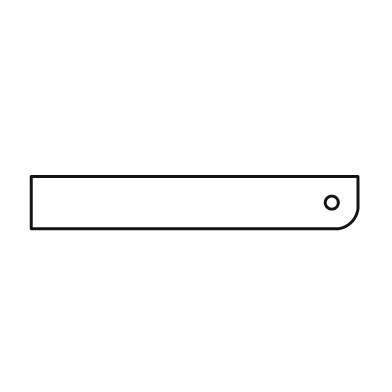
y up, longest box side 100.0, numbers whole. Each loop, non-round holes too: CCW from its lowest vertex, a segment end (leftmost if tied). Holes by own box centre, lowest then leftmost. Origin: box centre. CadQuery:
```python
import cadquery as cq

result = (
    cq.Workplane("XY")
    .moveTo(-50.0, -8.0)
    .lineTo(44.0, -8.0)
    .threePointArc((48.0, -6.0), (50.0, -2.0))
    .lineTo(50.0, 8.0)
    .lineTo(-50.0, 8.0)
    .close()
    .moveTo(42.0, 0.0)
    .circle(2.0)
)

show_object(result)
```